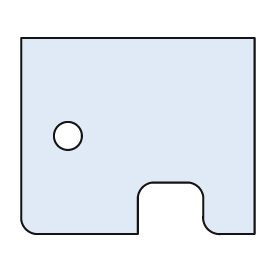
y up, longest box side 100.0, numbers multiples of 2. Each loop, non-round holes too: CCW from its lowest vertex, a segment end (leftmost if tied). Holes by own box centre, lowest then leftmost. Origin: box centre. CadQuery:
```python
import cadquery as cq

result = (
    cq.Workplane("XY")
    .moveTo(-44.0, -42.0)
    .lineTo(0.0, -42.0)
    .lineTo(0.0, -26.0)
    .threePointArc((2.0, -22.0), (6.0, -20.0))
    .lineTo(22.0, -20.0)
    .threePointArc((26.0, -22.0), (28.0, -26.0))
    .lineTo(28.0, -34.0)
    .threePointArc((30.0, -40.0), (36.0, -42.0))
    .lineTo(50.0, -42.0)
    .lineTo(50.0, 42.0)
    .lineTo(-50.0, 42.0)
    .lineTo(-50.0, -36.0)
    .threePointArc((-48.0, -40.0), (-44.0, -42.0))
    .close()
    .moveTo(-30.0, 0.0)
    .circle(6.0)
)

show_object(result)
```